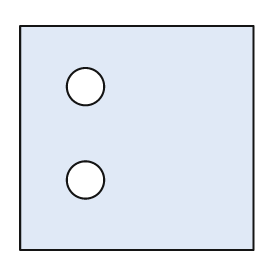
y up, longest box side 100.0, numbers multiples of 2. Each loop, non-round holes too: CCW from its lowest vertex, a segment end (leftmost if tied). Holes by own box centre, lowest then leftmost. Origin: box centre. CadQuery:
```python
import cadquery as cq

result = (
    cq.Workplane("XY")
    .moveTo(-50.0, -48.0)
    .lineTo(50.0, -48.0)
    .lineTo(50.0, 48.0)
    .lineTo(-50.0, 48.0)
    .close()
    .moveTo(-22.0, -18.0)
    .circle(8.0)
    .moveTo(-22.0, 22.0)
    .circle(8.0)
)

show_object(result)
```